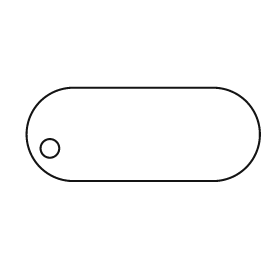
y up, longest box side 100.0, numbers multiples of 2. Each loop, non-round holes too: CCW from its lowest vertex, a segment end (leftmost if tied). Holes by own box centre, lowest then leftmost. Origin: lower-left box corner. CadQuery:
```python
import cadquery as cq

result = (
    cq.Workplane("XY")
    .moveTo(20.0, 0.0)
    .lineTo(80.0, 0.0)
    .threePointArc((100.0, 20.0), (80.0, 40.0))
    .lineTo(20.0, 40.0)
    .threePointArc((0.0, 20.0), (20.0, 0.0))
    .close()
    .moveTo(10.0, 14.0)
    .circle(4.0)
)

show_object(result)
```